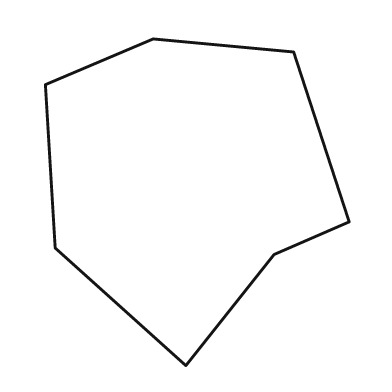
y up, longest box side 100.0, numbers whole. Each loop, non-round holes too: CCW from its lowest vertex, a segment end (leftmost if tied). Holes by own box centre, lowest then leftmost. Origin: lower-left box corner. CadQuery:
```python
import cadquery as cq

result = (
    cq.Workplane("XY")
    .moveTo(43.0, 0.0)
    .lineTo(70.0, 34.0)
    .lineTo(93.0, 44.0)
    .lineTo(76.0, 96.0)
    .lineTo(33.0, 100.0)
    .lineTo(0.0, 86.0)
    .lineTo(3.0, 36.0)
    .close()
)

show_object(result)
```